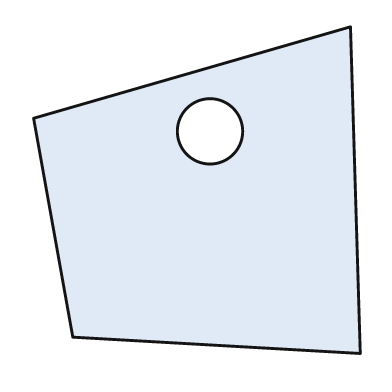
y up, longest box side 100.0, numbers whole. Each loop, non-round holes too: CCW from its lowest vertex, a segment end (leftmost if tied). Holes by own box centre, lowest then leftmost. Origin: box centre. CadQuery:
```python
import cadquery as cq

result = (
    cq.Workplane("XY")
    .moveTo(50.0, -50.0)
    .lineTo(47.0, 50.0)
    .lineTo(-50.0, 22.0)
    .lineTo(-38.0, -45.0)
    .close()
    .moveTo(4.0, 18.0)
    .circle(10.0)
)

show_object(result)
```